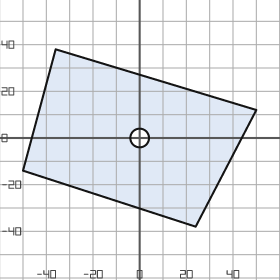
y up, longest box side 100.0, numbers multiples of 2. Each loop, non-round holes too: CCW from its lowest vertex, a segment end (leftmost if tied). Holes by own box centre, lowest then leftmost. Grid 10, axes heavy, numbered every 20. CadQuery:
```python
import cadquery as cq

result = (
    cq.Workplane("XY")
    .moveTo(24.0, -38.0)
    .lineTo(50.0, 12.0)
    .lineTo(-36.0, 38.0)
    .lineTo(-50.0, -14.0)
    .close()
    .moveTo(0.0, 0.0)
    .circle(4.0)
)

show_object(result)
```